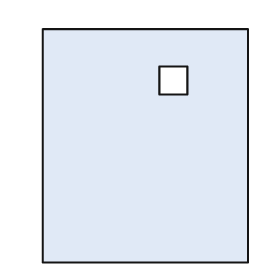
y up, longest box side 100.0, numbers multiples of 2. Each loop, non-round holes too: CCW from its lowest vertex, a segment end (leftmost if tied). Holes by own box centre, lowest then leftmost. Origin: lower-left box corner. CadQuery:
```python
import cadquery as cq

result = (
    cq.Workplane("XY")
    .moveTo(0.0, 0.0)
    .lineTo(88.0, 0.0)
    .lineTo(88.0, 100.0)
    .lineTo(0.0, 100.0)
    .close()
    .moveTo(50.0, 72.0)
    .lineTo(62.0, 72.0)
    .lineTo(62.0, 84.0)
    .lineTo(50.0, 84.0)
    .close()
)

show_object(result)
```